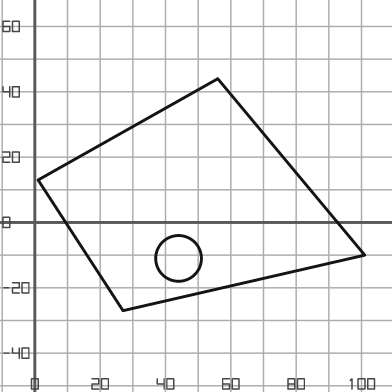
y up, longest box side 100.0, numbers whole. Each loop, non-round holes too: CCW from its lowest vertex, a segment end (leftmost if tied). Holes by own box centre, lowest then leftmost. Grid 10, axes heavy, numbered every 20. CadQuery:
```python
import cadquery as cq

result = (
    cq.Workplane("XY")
    .moveTo(27.0, -27.0)
    .lineTo(101.0, -10.0)
    .lineTo(56.0, 44.0)
    .lineTo(1.0, 13.0)
    .close()
    .moveTo(44.0, -11.0)
    .circle(7.0)
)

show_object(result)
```